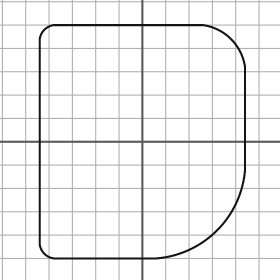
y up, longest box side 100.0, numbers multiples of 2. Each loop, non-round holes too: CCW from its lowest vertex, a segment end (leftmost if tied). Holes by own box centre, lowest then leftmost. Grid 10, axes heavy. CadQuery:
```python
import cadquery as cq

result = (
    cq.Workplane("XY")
    .moveTo(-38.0, -50.0)
    .lineTo(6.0, -50.0)
    .threePointArc((32.0, -38.0), (44.0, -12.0))
    .lineTo(44.0, 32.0)
    .threePointArc((38.0, 44.0), (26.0, 50.0))
    .lineTo(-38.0, 50.0)
    .threePointArc((-42.0, 48.0), (-44.0, 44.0))
    .lineTo(-44.0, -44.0)
    .threePointArc((-42.0, -48.0), (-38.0, -50.0))
    .close()
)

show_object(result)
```